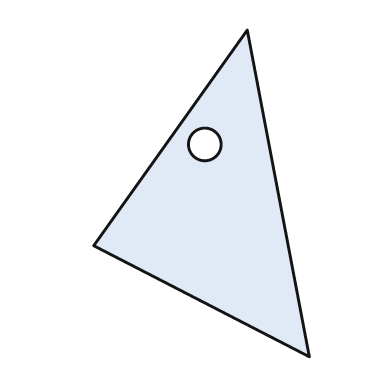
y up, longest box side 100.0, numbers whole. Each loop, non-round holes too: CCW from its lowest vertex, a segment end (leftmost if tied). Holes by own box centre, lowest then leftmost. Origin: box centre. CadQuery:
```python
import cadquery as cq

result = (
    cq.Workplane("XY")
    .moveTo(33.0, -50.0)
    .lineTo(14.0, 50.0)
    .lineTo(-33.0, -16.0)
    .close()
    .moveTo(1.0, 15.0)
    .circle(5.0)
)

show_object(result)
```